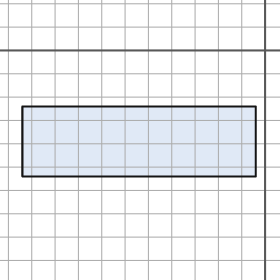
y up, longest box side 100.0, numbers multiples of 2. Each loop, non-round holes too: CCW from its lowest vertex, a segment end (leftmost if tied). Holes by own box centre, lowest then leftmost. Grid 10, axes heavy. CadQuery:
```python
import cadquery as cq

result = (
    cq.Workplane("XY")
    .moveTo(-104.0, -54.0)
    .lineTo(-4.0, -54.0)
    .lineTo(-4.0, -24.0)
    .lineTo(-104.0, -24.0)
    .close()
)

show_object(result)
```